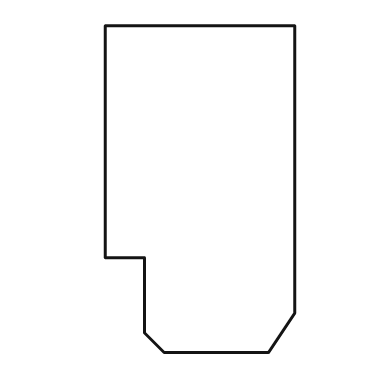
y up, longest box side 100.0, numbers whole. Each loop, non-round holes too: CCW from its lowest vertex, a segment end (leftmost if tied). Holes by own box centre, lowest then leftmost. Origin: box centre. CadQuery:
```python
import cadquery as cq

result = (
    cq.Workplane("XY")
    .moveTo(-11.0, -50.0)
    .lineTo(21.0, -50.0)
    .lineTo(29.0, -38.0)
    .lineTo(29.0, 50.0)
    .lineTo(-29.0, 50.0)
    .lineTo(-29.0, -21.0)
    .lineTo(-17.0, -21.0)
    .lineTo(-17.0, -44.0)
    .close()
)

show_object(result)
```